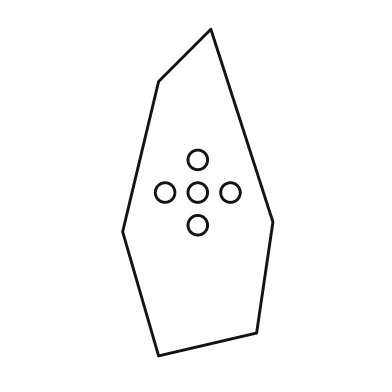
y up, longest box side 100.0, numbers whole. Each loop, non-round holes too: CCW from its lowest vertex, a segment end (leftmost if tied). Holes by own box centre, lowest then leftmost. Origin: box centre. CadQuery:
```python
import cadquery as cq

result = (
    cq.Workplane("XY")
    .moveTo(-12.0, -50.0)
    .lineTo(18.0, -43.0)
    .lineTo(23.0, -9.0)
    .lineTo(4.0, 50.0)
    .lineTo(-12.0, 34.0)
    .lineTo(-23.0, -12.0)
    .close()
    .moveTo(0.0, -10.0)
    .circle(3.0)
    .moveTo(-10.0, 0.0)
    .circle(3.0)
    .moveTo(0.0, 0.0)
    .circle(3.0)
    .moveTo(10.0, 0.0)
    .circle(3.0)
    .moveTo(0.0, 10.0)
    .circle(3.0)
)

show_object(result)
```